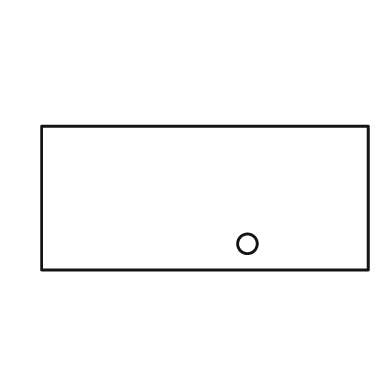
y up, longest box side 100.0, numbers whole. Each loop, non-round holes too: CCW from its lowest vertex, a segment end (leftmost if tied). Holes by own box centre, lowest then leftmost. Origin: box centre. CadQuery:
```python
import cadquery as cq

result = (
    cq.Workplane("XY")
    .moveTo(-50.0, -22.0)
    .lineTo(50.0, -22.0)
    .lineTo(50.0, 22.0)
    .lineTo(-50.0, 22.0)
    .close()
    .moveTo(13.0, -14.0)
    .circle(3.0)
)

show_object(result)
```